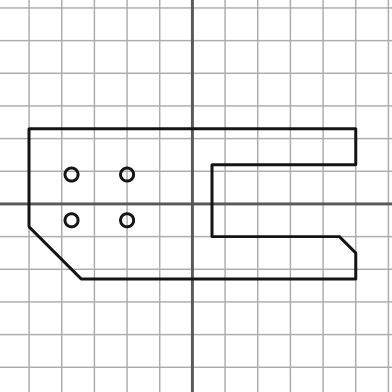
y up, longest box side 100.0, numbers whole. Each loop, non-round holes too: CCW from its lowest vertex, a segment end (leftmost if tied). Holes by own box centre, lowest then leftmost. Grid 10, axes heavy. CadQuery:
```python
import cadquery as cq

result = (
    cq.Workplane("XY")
    .moveTo(-34.0, -23.0)
    .lineTo(50.0, -23.0)
    .lineTo(50.0, -15.0)
    .lineTo(45.0, -10.0)
    .lineTo(6.0, -10.0)
    .lineTo(6.0, 12.0)
    .lineTo(50.0, 12.0)
    .lineTo(50.0, 23.0)
    .lineTo(-50.0, 23.0)
    .lineTo(-50.0, -7.0)
    .close()
    .moveTo(-37.0, -5.0)
    .circle(2.0)
    .moveTo(-20.0, -5.0)
    .circle(2.0)
    .moveTo(-37.0, 9.0)
    .circle(2.0)
    .moveTo(-20.0, 9.0)
    .circle(2.0)
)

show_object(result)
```